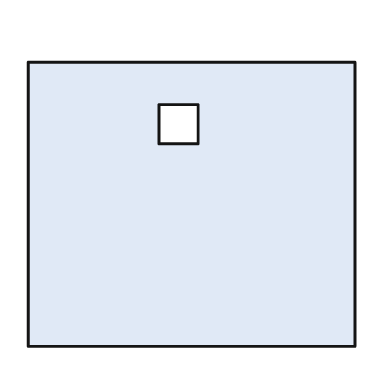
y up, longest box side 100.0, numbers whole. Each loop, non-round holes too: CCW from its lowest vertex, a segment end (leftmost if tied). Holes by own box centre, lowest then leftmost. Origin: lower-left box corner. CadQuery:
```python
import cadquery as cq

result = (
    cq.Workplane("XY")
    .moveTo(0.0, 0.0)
    .lineTo(100.0, 0.0)
    .lineTo(100.0, 87.0)
    .lineTo(0.0, 87.0)
    .close()
    .moveTo(40.0, 62.0)
    .lineTo(52.0, 62.0)
    .lineTo(52.0, 74.0)
    .lineTo(40.0, 74.0)
    .close()
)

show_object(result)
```